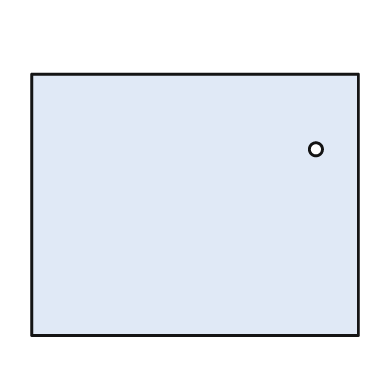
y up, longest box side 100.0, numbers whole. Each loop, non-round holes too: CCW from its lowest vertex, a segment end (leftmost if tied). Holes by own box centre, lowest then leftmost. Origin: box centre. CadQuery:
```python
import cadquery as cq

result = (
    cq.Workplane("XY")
    .moveTo(-50.0, -40.0)
    .lineTo(50.0, -40.0)
    .lineTo(50.0, 40.0)
    .lineTo(-50.0, 40.0)
    .close()
    .moveTo(37.0, 17.0)
    .circle(2.0)
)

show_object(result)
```